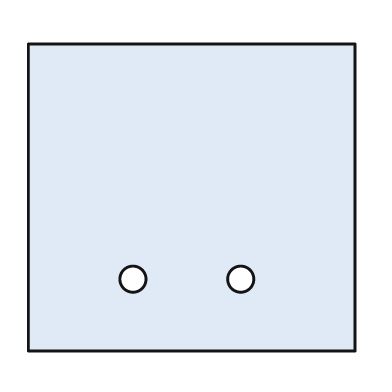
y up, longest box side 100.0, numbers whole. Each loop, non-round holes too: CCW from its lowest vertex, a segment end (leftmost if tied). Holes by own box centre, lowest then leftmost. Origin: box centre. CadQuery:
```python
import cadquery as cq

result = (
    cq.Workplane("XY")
    .moveTo(-50.0, -47.0)
    .lineTo(50.0, -47.0)
    .lineTo(50.0, 47.0)
    .lineTo(-50.0, 47.0)
    .close()
    .moveTo(-18.0, -25.0)
    .circle(4.0)
    .moveTo(15.0, -25.0)
    .circle(4.0)
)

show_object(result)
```